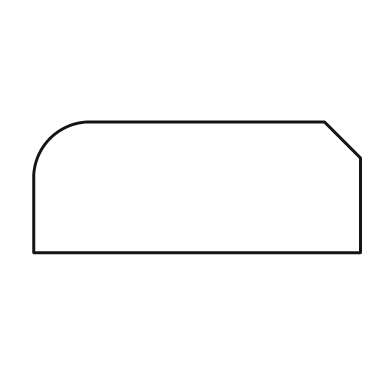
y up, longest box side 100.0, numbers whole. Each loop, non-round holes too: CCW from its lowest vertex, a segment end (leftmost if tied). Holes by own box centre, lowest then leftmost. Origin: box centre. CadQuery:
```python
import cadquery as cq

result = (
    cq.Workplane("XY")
    .moveTo(-50.0, -20.0)
    .lineTo(50.0, -20.0)
    .lineTo(50.0, 9.0)
    .lineTo(39.0, 20.0)
    .lineTo(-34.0, 20.0)
    .threePointArc((-45.0, 15.0), (-50.0, 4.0))
    .close()
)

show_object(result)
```